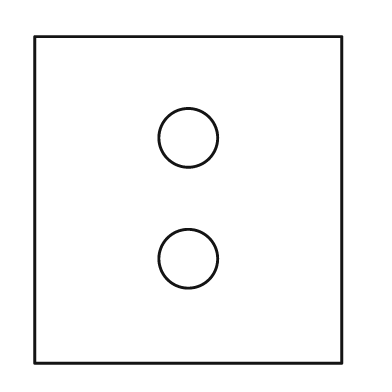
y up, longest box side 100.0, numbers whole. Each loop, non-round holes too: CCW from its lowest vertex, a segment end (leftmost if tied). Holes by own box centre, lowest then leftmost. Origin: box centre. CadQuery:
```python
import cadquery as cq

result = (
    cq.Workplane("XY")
    .moveTo(-47.0, -50.0)
    .lineTo(47.0, -50.0)
    .lineTo(47.0, 50.0)
    .lineTo(-47.0, 50.0)
    .close()
    .moveTo(0.0, -18.0)
    .circle(9.0)
    .moveTo(0.0, 19.0)
    .circle(9.0)
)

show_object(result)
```